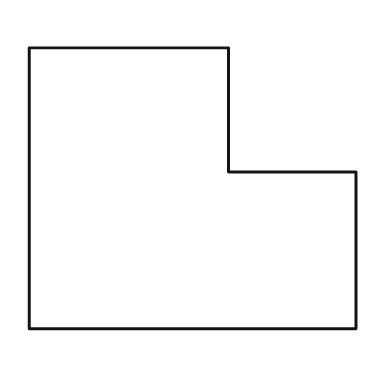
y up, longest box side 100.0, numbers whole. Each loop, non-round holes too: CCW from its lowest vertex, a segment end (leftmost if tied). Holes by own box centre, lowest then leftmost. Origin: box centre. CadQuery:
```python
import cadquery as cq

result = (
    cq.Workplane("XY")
    .moveTo(-50.0, -43.0)
    .lineTo(50.0, -43.0)
    .lineTo(50.0, 5.0)
    .lineTo(11.0, 5.0)
    .lineTo(11.0, 43.0)
    .lineTo(-50.0, 43.0)
    .close()
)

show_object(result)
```